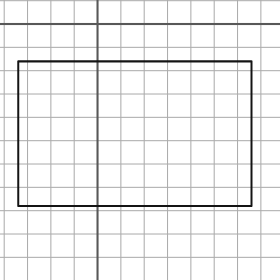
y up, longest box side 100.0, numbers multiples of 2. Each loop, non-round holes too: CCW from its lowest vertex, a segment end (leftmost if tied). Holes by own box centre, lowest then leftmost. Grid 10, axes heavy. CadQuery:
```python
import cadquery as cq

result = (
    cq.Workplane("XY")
    .moveTo(-34.0, -78.0)
    .lineTo(66.0, -78.0)
    .lineTo(66.0, -16.0)
    .lineTo(-34.0, -16.0)
    .close()
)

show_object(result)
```